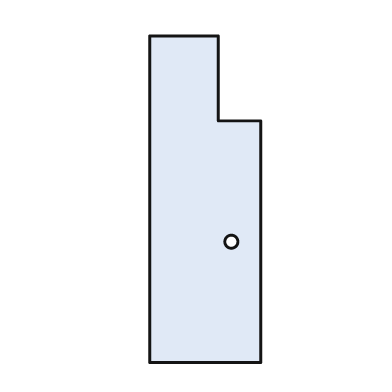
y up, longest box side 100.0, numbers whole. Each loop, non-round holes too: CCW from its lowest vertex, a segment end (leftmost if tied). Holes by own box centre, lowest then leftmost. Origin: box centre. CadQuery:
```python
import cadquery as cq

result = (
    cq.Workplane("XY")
    .moveTo(-17.0, -50.0)
    .lineTo(17.0, -50.0)
    .lineTo(17.0, 24.0)
    .lineTo(4.0, 24.0)
    .lineTo(4.0, 50.0)
    .lineTo(-17.0, 50.0)
    .close()
    .moveTo(8.0, -13.0)
    .circle(2.0)
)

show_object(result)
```